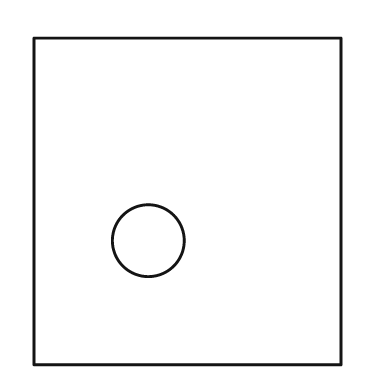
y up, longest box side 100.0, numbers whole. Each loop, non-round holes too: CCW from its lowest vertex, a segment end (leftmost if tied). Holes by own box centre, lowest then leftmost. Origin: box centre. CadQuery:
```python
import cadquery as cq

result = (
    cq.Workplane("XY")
    .moveTo(-47.0, -50.0)
    .lineTo(47.0, -50.0)
    .lineTo(47.0, 50.0)
    .lineTo(-47.0, 50.0)
    .close()
    .moveTo(-12.0, -12.0)
    .circle(11.0)
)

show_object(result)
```